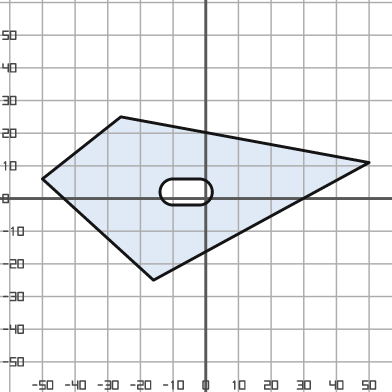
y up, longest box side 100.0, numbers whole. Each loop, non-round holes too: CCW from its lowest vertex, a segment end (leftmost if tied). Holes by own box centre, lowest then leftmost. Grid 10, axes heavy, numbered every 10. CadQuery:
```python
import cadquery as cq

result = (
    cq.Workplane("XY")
    .moveTo(-16.0, -25.0)
    .lineTo(50.0, 11.0)
    .lineTo(-26.0, 25.0)
    .lineTo(-50.0, 6.0)
    .close()
    .moveTo(-10.0, -2.0)
    .lineTo(-2.0, -2.0)
    .threePointArc((2.0, 2.0), (-2.0, 6.0))
    .lineTo(-10.0, 6.0)
    .threePointArc((-14.0, 2.0), (-10.0, -2.0))
    .close()
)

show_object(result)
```